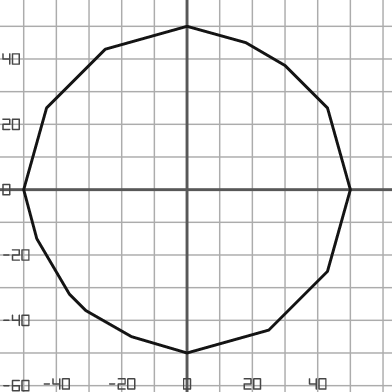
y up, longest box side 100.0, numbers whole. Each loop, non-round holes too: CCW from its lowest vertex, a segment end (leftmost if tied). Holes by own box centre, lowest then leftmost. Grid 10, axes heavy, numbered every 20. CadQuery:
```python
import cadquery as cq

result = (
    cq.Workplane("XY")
    .moveTo(0.0, -50.0)
    .lineTo(25.0, -43.0)
    .lineTo(43.0, -25.0)
    .lineTo(50.0, 0.0)
    .lineTo(43.0, 25.0)
    .lineTo(30.0, 38.0)
    .lineTo(18.0, 45.0)
    .lineTo(0.0, 50.0)
    .lineTo(-25.0, 43.0)
    .lineTo(-43.0, 25.0)
    .lineTo(-50.0, 0.0)
    .lineTo(-46.0, -15.0)
    .lineTo(-36.0, -32.0)
    .lineTo(-31.0, -37.0)
    .lineTo(-17.0, -45.0)
    .close()
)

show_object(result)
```